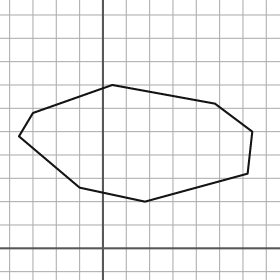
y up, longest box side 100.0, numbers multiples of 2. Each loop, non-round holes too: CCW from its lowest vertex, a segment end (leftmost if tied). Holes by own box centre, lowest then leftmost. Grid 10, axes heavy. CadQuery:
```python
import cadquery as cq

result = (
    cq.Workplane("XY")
    .moveTo(18.0, 20.0)
    .lineTo(62.0, 32.0)
    .lineTo(64.0, 50.0)
    .lineTo(48.0, 62.0)
    .lineTo(4.0, 70.0)
    .lineTo(-30.0, 58.0)
    .lineTo(-36.0, 48.0)
    .lineTo(-10.0, 26.0)
    .close()
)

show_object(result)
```